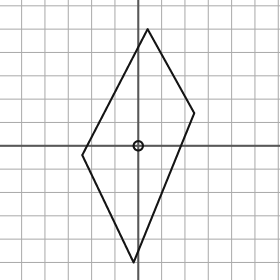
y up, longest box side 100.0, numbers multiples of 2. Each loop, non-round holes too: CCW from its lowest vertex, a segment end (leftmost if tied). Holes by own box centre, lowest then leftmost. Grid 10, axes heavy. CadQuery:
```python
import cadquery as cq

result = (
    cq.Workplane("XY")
    .moveTo(-2.0, -50.0)
    .lineTo(24.0, 14.0)
    .lineTo(4.0, 50.0)
    .lineTo(-24.0, -4.0)
    .close()
    .moveTo(0.0, 0.0)
    .circle(2.0)
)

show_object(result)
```